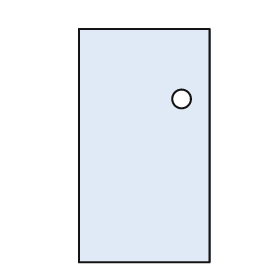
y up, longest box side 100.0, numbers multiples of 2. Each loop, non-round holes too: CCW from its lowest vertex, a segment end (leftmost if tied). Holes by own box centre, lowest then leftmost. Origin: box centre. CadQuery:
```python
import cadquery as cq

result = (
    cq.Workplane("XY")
    .moveTo(-28.0, -50.0)
    .lineTo(28.0, -50.0)
    .lineTo(28.0, 50.0)
    .lineTo(-28.0, 50.0)
    .close()
    .moveTo(16.0, 20.0)
    .circle(4.0)
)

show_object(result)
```